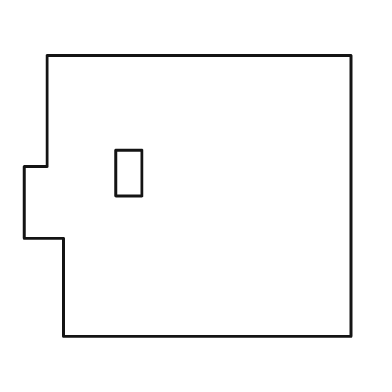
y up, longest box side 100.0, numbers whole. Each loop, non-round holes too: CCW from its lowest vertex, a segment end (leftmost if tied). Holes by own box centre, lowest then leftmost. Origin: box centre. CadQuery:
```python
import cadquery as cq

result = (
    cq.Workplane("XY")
    .moveTo(-38.0, -43.0)
    .lineTo(50.0, -43.0)
    .lineTo(50.0, 43.0)
    .lineTo(-43.0, 43.0)
    .lineTo(-43.0, 9.0)
    .lineTo(-50.0, 9.0)
    .lineTo(-50.0, -13.0)
    .lineTo(-38.0, -13.0)
    .close()
    .moveTo(-22.0, 0.0)
    .lineTo(-14.0, 0.0)
    .lineTo(-14.0, 14.0)
    .lineTo(-22.0, 14.0)
    .close()
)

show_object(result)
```